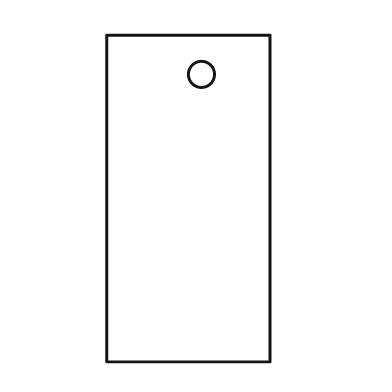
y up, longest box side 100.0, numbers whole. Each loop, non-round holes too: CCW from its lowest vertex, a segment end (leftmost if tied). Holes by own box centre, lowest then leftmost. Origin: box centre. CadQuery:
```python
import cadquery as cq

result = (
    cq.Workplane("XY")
    .moveTo(-25.0, -50.0)
    .lineTo(25.0, -50.0)
    .lineTo(25.0, 50.0)
    .lineTo(-25.0, 50.0)
    .close()
    .moveTo(4.0, 38.0)
    .circle(4.0)
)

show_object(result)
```